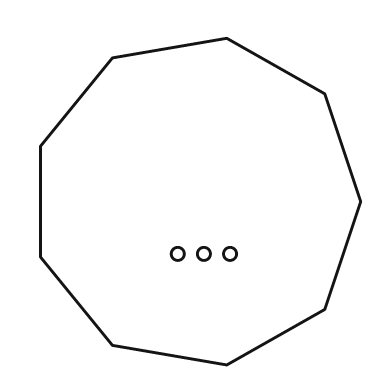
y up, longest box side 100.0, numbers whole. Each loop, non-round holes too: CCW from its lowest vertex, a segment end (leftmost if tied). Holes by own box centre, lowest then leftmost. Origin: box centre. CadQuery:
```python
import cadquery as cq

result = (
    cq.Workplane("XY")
    .moveTo(8.0, -50.0)
    .lineTo(38.0, -33.0)
    .lineTo(49.0, 0.0)
    .lineTo(38.0, 33.0)
    .lineTo(8.0, 50.0)
    .lineTo(-27.0, 44.0)
    .lineTo(-49.0, 17.0)
    .lineTo(-49.0, -17.0)
    .lineTo(-27.0, -44.0)
    .close()
    .moveTo(-7.0, -16.0)
    .circle(2.0)
    .moveTo(1.0, -16.0)
    .circle(2.0)
    .moveTo(9.0, -16.0)
    .circle(2.0)
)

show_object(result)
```